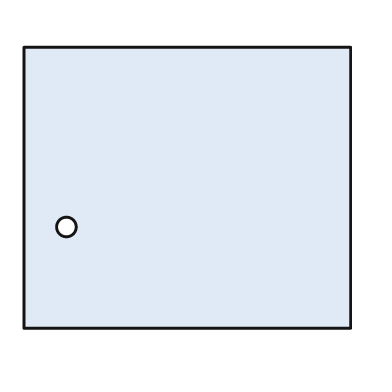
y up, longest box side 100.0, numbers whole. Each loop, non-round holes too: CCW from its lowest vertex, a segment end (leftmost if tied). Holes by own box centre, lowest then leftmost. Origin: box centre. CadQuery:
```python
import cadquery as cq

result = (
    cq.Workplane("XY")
    .moveTo(-50.0, -43.0)
    .lineTo(50.0, -43.0)
    .lineTo(50.0, 43.0)
    .lineTo(-50.0, 43.0)
    .close()
    .moveTo(-37.0, -12.0)
    .circle(3.0)
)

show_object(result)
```